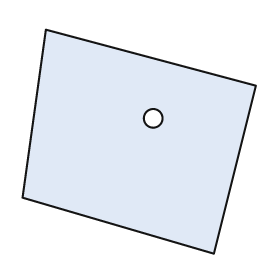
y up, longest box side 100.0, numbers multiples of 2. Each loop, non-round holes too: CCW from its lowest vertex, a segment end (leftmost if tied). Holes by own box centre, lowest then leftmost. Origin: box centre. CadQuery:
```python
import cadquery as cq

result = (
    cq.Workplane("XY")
    .moveTo(32.0, -48.0)
    .lineTo(50.0, 24.0)
    .lineTo(-40.0, 48.0)
    .lineTo(-50.0, -24.0)
    .close()
    .moveTo(6.0, 10.0)
    .circle(4.0)
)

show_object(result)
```